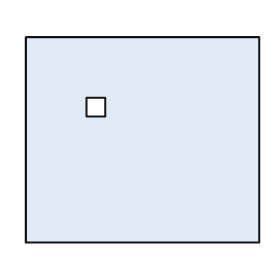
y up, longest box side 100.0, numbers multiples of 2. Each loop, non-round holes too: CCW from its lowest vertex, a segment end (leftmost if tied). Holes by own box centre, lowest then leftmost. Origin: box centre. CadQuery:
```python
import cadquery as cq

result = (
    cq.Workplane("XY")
    .moveTo(-50.0, -44.0)
    .lineTo(50.0, -44.0)
    .lineTo(50.0, 44.0)
    .lineTo(-50.0, 44.0)
    .close()
    .moveTo(-24.0, 10.0)
    .lineTo(-16.0, 10.0)
    .lineTo(-16.0, 18.0)
    .lineTo(-24.0, 18.0)
    .close()
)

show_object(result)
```